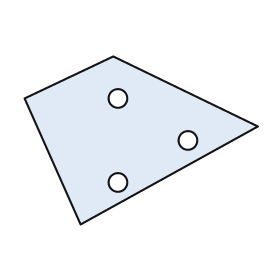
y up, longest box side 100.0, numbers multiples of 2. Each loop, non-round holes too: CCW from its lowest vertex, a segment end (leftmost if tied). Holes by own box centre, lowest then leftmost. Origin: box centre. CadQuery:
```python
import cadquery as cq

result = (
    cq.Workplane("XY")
    .moveTo(-26.0, -36.0)
    .lineTo(50.0, 6.0)
    .lineTo(-12.0, 36.0)
    .lineTo(-50.0, 18.0)
    .close()
    .moveTo(-10.0, -18.0)
    .circle(4.0)
    .moveTo(20.0, 0.0)
    .circle(4.0)
    .moveTo(-10.0, 18.0)
    .circle(4.0)
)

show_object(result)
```